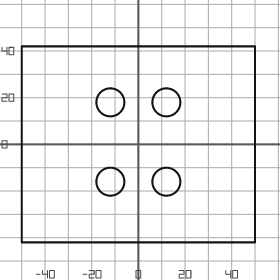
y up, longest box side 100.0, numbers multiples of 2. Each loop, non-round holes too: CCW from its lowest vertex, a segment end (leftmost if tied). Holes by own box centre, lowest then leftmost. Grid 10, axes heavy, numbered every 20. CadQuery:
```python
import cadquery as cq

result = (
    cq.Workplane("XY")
    .moveTo(-50.0, -42.0)
    .lineTo(50.0, -42.0)
    .lineTo(50.0, 42.0)
    .lineTo(-50.0, 42.0)
    .close()
    .moveTo(-12.0, -16.0)
    .circle(6.0)
    .moveTo(12.0, -16.0)
    .circle(6.0)
    .moveTo(-12.0, 18.0)
    .circle(6.0)
    .moveTo(12.0, 18.0)
    .circle(6.0)
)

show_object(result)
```